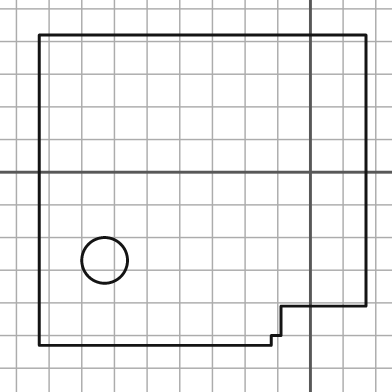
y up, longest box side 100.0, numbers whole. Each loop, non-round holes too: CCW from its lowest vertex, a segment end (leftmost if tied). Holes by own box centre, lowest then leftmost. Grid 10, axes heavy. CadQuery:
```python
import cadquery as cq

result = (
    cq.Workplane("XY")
    .moveTo(-83.0, -53.0)
    .lineTo(-12.0, -53.0)
    .lineTo(-12.0, -50.0)
    .lineTo(-9.0, -50.0)
    .lineTo(-9.0, -41.0)
    .lineTo(17.0, -41.0)
    .lineTo(17.0, 42.0)
    .lineTo(-83.0, 42.0)
    .close()
    .moveTo(-63.0, -27.0)
    .circle(7.0)
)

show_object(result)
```